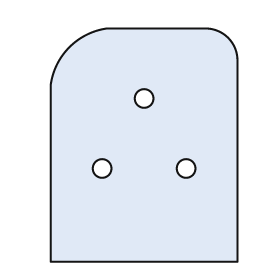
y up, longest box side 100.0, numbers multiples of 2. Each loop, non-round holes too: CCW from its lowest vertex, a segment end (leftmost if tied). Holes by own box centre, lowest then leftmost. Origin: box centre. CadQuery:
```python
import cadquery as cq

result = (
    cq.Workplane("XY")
    .moveTo(-40.0, -50.0)
    .lineTo(40.0, -50.0)
    .lineTo(40.0, 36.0)
    .threePointArc((36.0, 46.0), (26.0, 50.0))
    .lineTo(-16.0, 50.0)
    .threePointArc((-32.0, 42.0), (-40.0, 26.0))
    .close()
    .moveTo(-18.0, -10.0)
    .circle(4.0)
    .moveTo(18.0, -10.0)
    .circle(4.0)
    .moveTo(0.0, 20.0)
    .circle(4.0)
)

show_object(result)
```